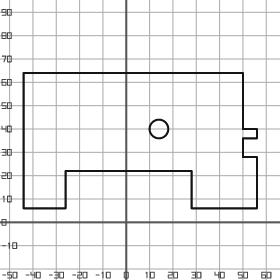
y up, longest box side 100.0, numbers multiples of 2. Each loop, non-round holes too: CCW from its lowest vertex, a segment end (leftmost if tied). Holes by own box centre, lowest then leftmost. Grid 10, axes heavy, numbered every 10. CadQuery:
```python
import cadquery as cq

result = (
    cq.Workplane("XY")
    .moveTo(-44.0, 6.0)
    .lineTo(-26.0, 6.0)
    .lineTo(-26.0, 22.0)
    .lineTo(28.0, 22.0)
    .lineTo(28.0, 6.0)
    .lineTo(56.0, 6.0)
    .lineTo(56.0, 28.0)
    .lineTo(50.0, 28.0)
    .lineTo(50.0, 36.0)
    .lineTo(56.0, 36.0)
    .lineTo(56.0, 40.0)
    .lineTo(50.0, 40.0)
    .lineTo(50.0, 64.0)
    .lineTo(-44.0, 64.0)
    .close()
    .moveTo(14.0, 40.0)
    .circle(4.0)
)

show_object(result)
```